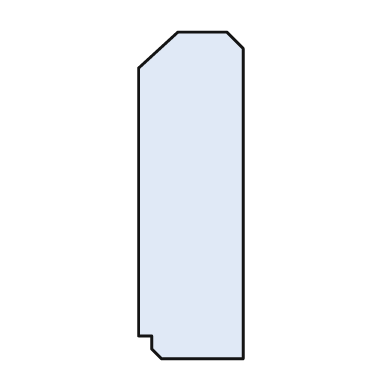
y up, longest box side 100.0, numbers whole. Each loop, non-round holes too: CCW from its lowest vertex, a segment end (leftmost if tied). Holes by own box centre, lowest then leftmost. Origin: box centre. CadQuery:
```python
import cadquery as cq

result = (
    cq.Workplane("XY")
    .moveTo(-9.0, -50.0)
    .lineTo(16.0, -50.0)
    .lineTo(16.0, 45.0)
    .lineTo(11.0, 50.0)
    .lineTo(-4.0, 50.0)
    .lineTo(-16.0, 39.0)
    .lineTo(-16.0, -43.0)
    .lineTo(-12.0, -43.0)
    .lineTo(-12.0, -47.0)
    .close()
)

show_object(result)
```